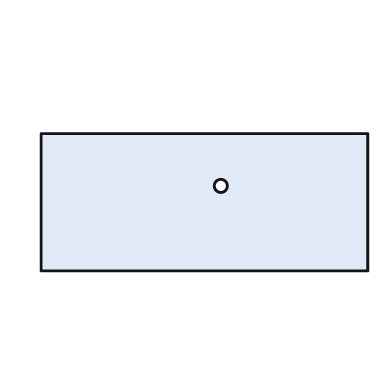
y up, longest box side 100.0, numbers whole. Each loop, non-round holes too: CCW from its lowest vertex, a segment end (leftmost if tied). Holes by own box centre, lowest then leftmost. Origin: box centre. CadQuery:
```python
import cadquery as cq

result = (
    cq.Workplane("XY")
    .moveTo(-50.0, -21.0)
    .lineTo(50.0, -21.0)
    .lineTo(50.0, 21.0)
    .lineTo(-50.0, 21.0)
    .close()
    .moveTo(5.0, 5.0)
    .circle(2.0)
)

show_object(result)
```